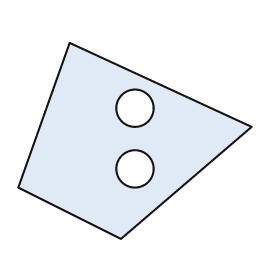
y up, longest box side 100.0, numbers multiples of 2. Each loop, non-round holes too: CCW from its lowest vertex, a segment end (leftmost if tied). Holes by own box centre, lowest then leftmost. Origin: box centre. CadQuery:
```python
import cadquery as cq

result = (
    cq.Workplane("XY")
    .moveTo(-6.0, -42.0)
    .lineTo(50.0, 6.0)
    .lineTo(-28.0, 42.0)
    .lineTo(-50.0, -20.0)
    .close()
    .moveTo(0.0, -12.0)
    .circle(8.0)
    .moveTo(0.0, 14.0)
    .circle(8.0)
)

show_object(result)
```